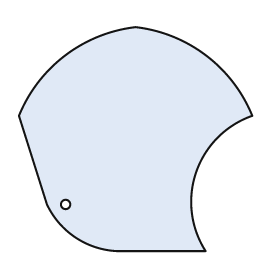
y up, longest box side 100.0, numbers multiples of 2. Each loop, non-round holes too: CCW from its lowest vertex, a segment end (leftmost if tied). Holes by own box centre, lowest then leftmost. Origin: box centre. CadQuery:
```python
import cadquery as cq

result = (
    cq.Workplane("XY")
    .moveTo(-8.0, -48.0)
    .lineTo(30.0, -48.0)
    .threePointArc((26.0, -14.0), (50.0, 10.0))
    .threePointArc((30.0, 36.0), (0.0, 48.0))
    .threePointArc((-30.0, 36.0), (-50.0, 10.0))
    .lineTo(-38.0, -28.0)
    .threePointArc((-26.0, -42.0), (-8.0, -48.0))
    .close()
    .moveTo(-30.0, -28.0)
    .circle(2.0)
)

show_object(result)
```